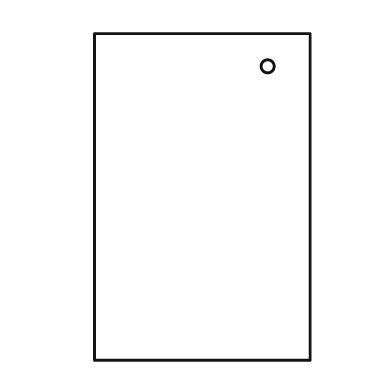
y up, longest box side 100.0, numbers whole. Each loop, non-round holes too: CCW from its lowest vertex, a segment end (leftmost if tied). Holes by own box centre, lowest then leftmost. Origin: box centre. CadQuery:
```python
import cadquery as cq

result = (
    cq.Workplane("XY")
    .moveTo(-33.0, -50.0)
    .lineTo(33.0, -50.0)
    .lineTo(33.0, 50.0)
    .lineTo(-33.0, 50.0)
    .close()
    .moveTo(20.0, 40.0)
    .circle(2.0)
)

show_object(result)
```